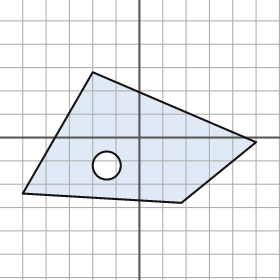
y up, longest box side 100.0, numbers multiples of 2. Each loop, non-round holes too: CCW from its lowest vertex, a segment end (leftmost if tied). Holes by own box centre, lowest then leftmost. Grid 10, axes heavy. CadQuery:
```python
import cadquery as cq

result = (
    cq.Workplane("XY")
    .moveTo(18.0, -28.0)
    .lineTo(50.0, -2.0)
    .lineTo(-20.0, 28.0)
    .lineTo(-50.0, -24.0)
    .close()
    .moveTo(-14.0, -12.0)
    .circle(6.0)
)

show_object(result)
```